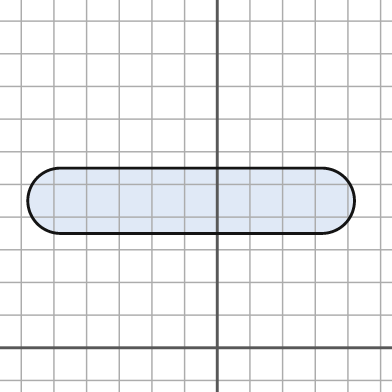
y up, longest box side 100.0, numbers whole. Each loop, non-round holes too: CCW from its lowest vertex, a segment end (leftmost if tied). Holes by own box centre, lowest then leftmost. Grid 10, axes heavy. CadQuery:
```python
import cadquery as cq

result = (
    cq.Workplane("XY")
    .moveTo(-48.0, 35.0)
    .lineTo(32.0, 35.0)
    .threePointArc((42.0, 45.0), (32.0, 55.0))
    .lineTo(-48.0, 55.0)
    .threePointArc((-58.0, 45.0), (-48.0, 35.0))
    .close()
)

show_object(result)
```